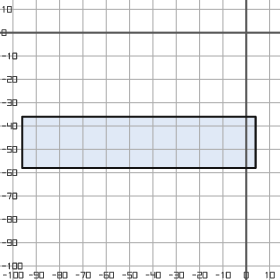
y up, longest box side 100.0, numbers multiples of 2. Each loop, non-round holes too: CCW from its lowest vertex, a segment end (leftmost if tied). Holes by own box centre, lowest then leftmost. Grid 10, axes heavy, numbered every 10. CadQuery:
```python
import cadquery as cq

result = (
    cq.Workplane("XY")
    .moveTo(-96.0, -58.0)
    .lineTo(4.0, -58.0)
    .lineTo(4.0, -36.0)
    .lineTo(-96.0, -36.0)
    .close()
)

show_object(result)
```